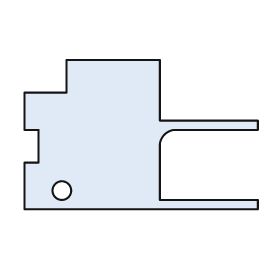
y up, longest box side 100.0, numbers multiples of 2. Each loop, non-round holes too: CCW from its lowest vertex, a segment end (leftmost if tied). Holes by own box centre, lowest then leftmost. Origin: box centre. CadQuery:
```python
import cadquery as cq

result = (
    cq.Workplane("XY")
    .moveTo(-50.0, -32.0)
    .lineTo(50.0, -32.0)
    .lineTo(50.0, -28.0)
    .lineTo(8.0, -28.0)
    .lineTo(8.0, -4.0)
    .threePointArc((10.0, 0.0), (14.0, 2.0))
    .lineTo(50.0, 2.0)
    .lineTo(50.0, 6.0)
    .lineTo(8.0, 6.0)
    .lineTo(8.0, 32.0)
    .lineTo(-32.0, 32.0)
    .lineTo(-32.0, 18.0)
    .lineTo(-50.0, 18.0)
    .lineTo(-50.0, 2.0)
    .lineTo(-44.0, 2.0)
    .lineTo(-44.0, -12.0)
    .lineTo(-50.0, -12.0)
    .close()
    .moveTo(-34.0, -24.0)
    .circle(4.0)
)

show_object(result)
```